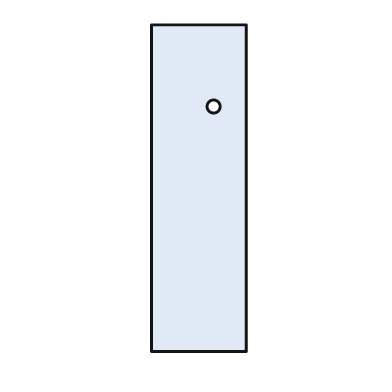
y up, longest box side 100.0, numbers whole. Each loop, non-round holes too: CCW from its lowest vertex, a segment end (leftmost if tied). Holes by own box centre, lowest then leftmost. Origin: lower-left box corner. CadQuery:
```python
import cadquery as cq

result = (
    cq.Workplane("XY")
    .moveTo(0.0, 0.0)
    .lineTo(29.0, 0.0)
    .lineTo(29.0, 100.0)
    .lineTo(0.0, 100.0)
    .close()
    .moveTo(19.0, 75.0)
    .circle(2.0)
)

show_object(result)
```